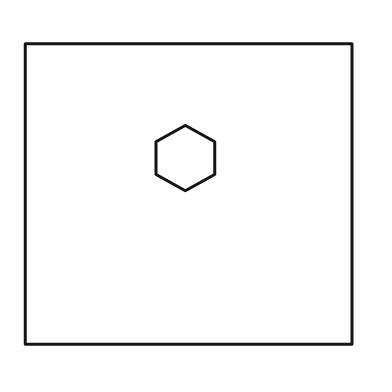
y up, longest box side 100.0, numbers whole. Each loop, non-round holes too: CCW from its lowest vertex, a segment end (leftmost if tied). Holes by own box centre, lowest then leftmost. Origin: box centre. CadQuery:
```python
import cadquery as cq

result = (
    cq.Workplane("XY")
    .moveTo(-50.0, -46.0)
    .lineTo(50.0, -46.0)
    .lineTo(50.0, 46.0)
    .lineTo(-50.0, 46.0)
    .close()
    .moveTo(-1.0, 1.0)
    .lineTo(8.0, 6.0)
    .lineTo(8.0, 16.0)
    .lineTo(-1.0, 21.0)
    .lineTo(-10.0, 16.0)
    .lineTo(-10.0, 6.0)
    .close()
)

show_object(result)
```